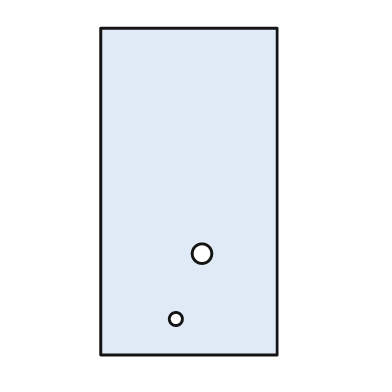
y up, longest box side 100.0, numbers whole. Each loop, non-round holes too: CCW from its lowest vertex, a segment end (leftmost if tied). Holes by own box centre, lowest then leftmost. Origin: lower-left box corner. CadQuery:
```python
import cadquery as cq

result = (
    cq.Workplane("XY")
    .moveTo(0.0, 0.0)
    .lineTo(54.0, 0.0)
    .lineTo(54.0, 100.0)
    .lineTo(0.0, 100.0)
    .close()
    .moveTo(23.0, 11.0)
    .circle(2.0)
    .moveTo(31.0, 31.0)
    .circle(3.0)
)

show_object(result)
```